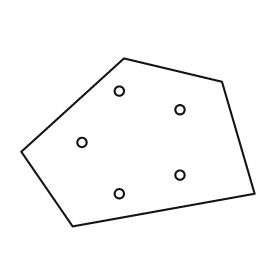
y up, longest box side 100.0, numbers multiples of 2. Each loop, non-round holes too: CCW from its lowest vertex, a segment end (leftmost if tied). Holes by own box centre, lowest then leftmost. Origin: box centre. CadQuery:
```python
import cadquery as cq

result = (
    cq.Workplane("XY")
    .moveTo(-28.0, -36.0)
    .lineTo(50.0, -22.0)
    .lineTo(36.0, 26.0)
    .lineTo(-6.0, 36.0)
    .lineTo(-50.0, -4.0)
    .close()
    .moveTo(-8.0, -22.0)
    .circle(2.0)
    .moveTo(18.0, -14.0)
    .circle(2.0)
    .moveTo(-24.0, 0.0)
    .circle(2.0)
    .moveTo(18.0, 14.0)
    .circle(2.0)
    .moveTo(-8.0, 22.0)
    .circle(2.0)
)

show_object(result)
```